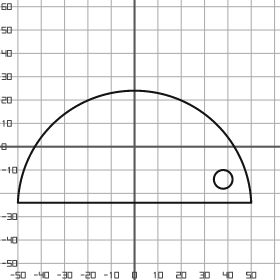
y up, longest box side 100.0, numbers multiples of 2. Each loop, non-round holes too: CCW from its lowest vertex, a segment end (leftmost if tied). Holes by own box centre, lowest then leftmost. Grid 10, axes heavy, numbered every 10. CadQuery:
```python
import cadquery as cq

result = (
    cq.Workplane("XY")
    .moveTo(-50.0, -24.0)
    .lineTo(50.0, -24.0)
    .threePointArc((0.0, 24.0), (-50.0, -24.0))
    .close()
    .moveTo(38.0, -14.0)
    .circle(4.0)
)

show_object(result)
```